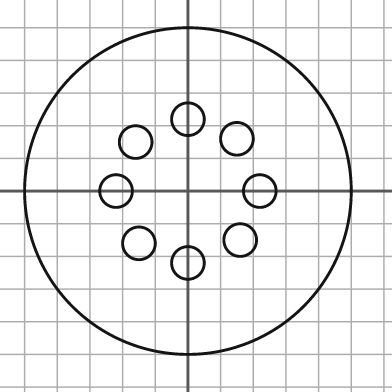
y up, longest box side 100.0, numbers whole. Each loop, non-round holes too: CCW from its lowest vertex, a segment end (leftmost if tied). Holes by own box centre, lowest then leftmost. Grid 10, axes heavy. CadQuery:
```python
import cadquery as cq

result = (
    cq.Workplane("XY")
    .moveTo(0.0, 0.0)
    .circle(50.0)
    .moveTo(0.0, -22.0)
    .circle(5.0)
    .moveTo(-15.0, -16.0)
    .circle(5.0)
    .moveTo(16.0, -15.0)
    .circle(5.0)
    .moveTo(-22.0, 0.0)
    .circle(5.0)
    .moveTo(22.0, 0.0)
    .circle(5.0)
    .moveTo(-16.0, 15.0)
    .circle(5.0)
    .moveTo(15.0, 16.0)
    .circle(5.0)
    .moveTo(0.0, 22.0)
    .circle(5.0)
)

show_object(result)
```